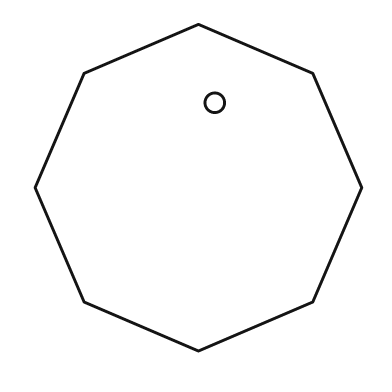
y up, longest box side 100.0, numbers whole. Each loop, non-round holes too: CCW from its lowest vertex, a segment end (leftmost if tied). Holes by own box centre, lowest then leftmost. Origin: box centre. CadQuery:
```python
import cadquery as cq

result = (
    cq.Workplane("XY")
    .moveTo(0.0, -50.0)
    .lineTo(35.0, -35.0)
    .lineTo(50.0, 0.0)
    .lineTo(35.0, 35.0)
    .lineTo(0.0, 50.0)
    .lineTo(-35.0, 35.0)
    .lineTo(-50.0, 0.0)
    .lineTo(-35.0, -35.0)
    .close()
    .moveTo(5.0, 26.0)
    .circle(3.0)
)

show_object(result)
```